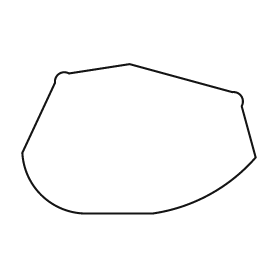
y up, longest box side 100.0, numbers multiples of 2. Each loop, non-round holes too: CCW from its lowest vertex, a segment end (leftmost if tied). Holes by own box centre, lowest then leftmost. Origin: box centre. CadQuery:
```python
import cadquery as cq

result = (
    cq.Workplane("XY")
    .moveTo(-24.0, -32.0)
    .lineTo(6.0, -32.0)
    .threePointArc((30.0, -24.0), (50.0, -8.0))
    .lineTo(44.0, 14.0)
    .threePointArc((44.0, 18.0), (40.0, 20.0))
    .lineTo(-4.0, 32.0)
    .lineTo(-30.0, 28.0)
    .threePointArc((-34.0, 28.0), (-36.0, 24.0))
    .lineTo(-50.0, -6.0)
    .threePointArc((-42.0, -24.0), (-24.0, -32.0))
    .close()
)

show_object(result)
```